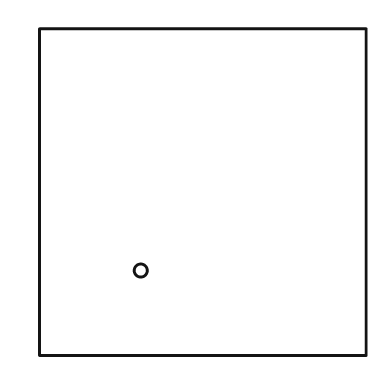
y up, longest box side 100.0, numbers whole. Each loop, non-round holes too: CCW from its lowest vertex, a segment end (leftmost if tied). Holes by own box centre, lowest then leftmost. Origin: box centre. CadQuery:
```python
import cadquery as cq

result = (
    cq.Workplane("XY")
    .moveTo(-50.0, -50.0)
    .lineTo(50.0, -50.0)
    .lineTo(50.0, 50.0)
    .lineTo(-50.0, 50.0)
    .close()
    .moveTo(-19.0, -24.0)
    .circle(2.0)
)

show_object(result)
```